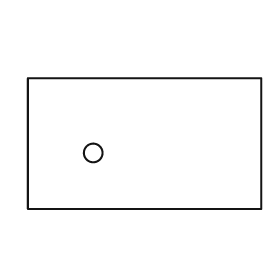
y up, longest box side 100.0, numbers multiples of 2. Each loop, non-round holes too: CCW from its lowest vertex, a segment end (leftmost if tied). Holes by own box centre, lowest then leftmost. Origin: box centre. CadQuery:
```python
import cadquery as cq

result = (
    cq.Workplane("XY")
    .moveTo(-50.0, -28.0)
    .lineTo(50.0, -28.0)
    .lineTo(50.0, 28.0)
    .lineTo(-50.0, 28.0)
    .close()
    .moveTo(-22.0, -4.0)
    .circle(4.0)
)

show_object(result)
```